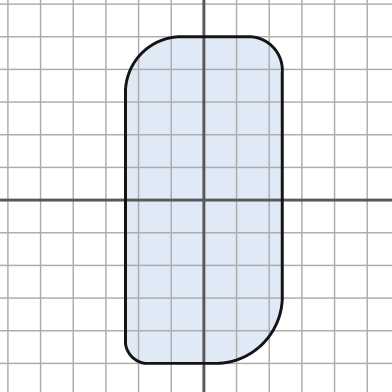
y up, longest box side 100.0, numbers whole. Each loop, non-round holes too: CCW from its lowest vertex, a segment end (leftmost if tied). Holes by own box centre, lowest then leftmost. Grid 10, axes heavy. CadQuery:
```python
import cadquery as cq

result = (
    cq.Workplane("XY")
    .moveTo(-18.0, -50.0)
    .lineTo(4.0, -50.0)
    .threePointArc((18.0, -44.0), (24.0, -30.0))
    .lineTo(24.0, 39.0)
    .threePointArc((21.0, 47.0), (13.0, 50.0))
    .lineTo(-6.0, 50.0)
    .threePointArc((-19.0, 45.0), (-24.0, 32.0))
    .lineTo(-24.0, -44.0)
    .threePointArc((-22.0, -48.0), (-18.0, -50.0))
    .close()
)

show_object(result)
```